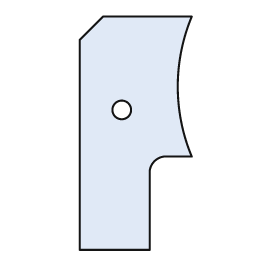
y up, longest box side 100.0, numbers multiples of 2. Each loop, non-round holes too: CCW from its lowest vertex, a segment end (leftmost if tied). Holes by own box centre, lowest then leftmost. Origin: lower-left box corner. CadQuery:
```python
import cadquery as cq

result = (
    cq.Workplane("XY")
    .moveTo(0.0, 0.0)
    .lineTo(30.0, 0.0)
    .lineTo(30.0, 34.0)
    .threePointArc((32.0, 38.0), (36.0, 40.0))
    .lineTo(48.0, 40.0)
    .threePointArc((42.0, 70.0), (48.0, 100.0))
    .lineTo(10.0, 100.0)
    .lineTo(0.0, 90.0)
    .close()
    .moveTo(18.0, 60.0)
    .circle(4.0)
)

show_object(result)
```